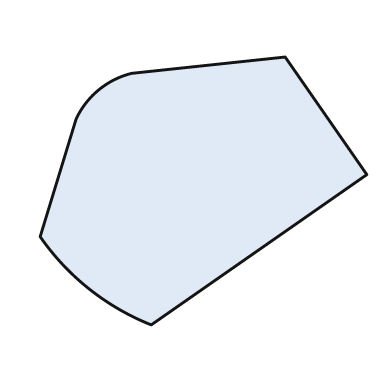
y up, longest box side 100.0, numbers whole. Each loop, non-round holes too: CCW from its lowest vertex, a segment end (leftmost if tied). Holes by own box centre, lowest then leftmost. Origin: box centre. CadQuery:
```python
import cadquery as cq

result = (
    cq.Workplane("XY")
    .moveTo(-16.0, -41.0)
    .lineTo(50.0, 5.0)
    .lineTo(25.0, 41.0)
    .lineTo(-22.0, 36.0)
    .threePointArc((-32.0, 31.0), (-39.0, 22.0))
    .lineTo(-50.0, -14.0)
    .threePointArc((-35.0, -30.0), (-16.0, -41.0))
    .close()
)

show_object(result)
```